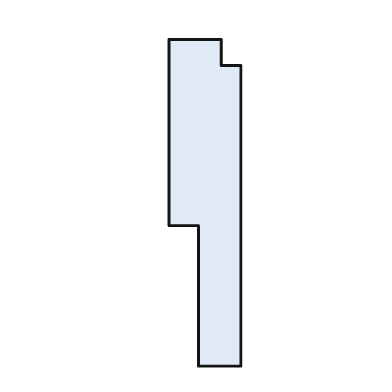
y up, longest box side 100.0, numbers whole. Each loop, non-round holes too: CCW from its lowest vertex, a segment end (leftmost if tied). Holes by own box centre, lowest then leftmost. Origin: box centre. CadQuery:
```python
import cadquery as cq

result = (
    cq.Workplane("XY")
    .moveTo(-2.0, -50.0)
    .lineTo(11.0, -50.0)
    .lineTo(11.0, 42.0)
    .lineTo(5.0, 42.0)
    .lineTo(5.0, 50.0)
    .lineTo(-11.0, 50.0)
    .lineTo(-11.0, -7.0)
    .lineTo(-2.0, -7.0)
    .close()
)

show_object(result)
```